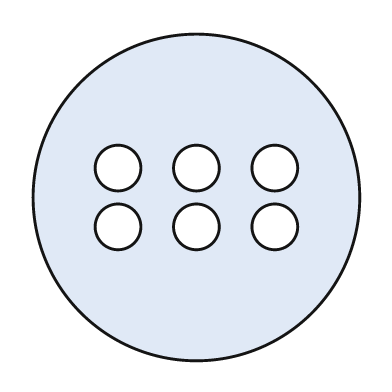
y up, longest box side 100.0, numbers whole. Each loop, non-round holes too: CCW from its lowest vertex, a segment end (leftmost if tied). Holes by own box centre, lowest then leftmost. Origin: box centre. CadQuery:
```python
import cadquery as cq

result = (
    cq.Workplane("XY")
    .moveTo(0.0, 0.0)
    .circle(50.0)
    .moveTo(-24.0, -9.0)
    .circle(7.0)
    .moveTo(0.0, -9.0)
    .circle(7.0)
    .moveTo(24.0, -9.0)
    .circle(7.0)
    .moveTo(-24.0, 9.0)
    .circle(7.0)
    .moveTo(0.0, 9.0)
    .circle(7.0)
    .moveTo(24.0, 9.0)
    .circle(7.0)
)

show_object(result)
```